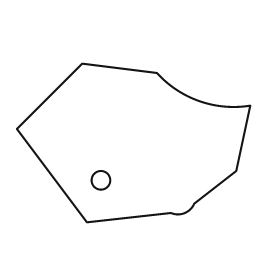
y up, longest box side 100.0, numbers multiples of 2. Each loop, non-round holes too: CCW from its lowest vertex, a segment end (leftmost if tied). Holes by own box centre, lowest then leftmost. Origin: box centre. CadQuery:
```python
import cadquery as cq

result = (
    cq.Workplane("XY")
    .moveTo(-20.0, -34.0)
    .lineTo(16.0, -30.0)
    .threePointArc((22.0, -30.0), (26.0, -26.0))
    .lineTo(44.0, -12.0)
    .lineTo(50.0, 16.0)
    .threePointArc((28.0, 18.0), (10.0, 30.0))
    .lineTo(-22.0, 34.0)
    .lineTo(-50.0, 6.0)
    .close()
    .moveTo(-14.0, -16.0)
    .circle(4.0)
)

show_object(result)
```